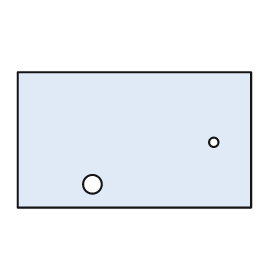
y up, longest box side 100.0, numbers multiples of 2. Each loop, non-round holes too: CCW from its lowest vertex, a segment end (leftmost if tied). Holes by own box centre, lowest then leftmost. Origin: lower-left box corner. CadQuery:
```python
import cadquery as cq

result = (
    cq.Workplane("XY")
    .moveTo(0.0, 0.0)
    .lineTo(100.0, 0.0)
    .lineTo(100.0, 58.0)
    .lineTo(0.0, 58.0)
    .close()
    .moveTo(32.0, 10.0)
    .circle(4.0)
    .moveTo(84.0, 28.0)
    .circle(2.0)
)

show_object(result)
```